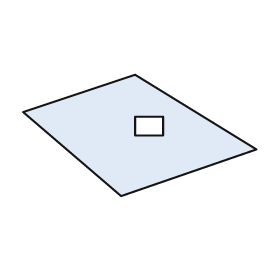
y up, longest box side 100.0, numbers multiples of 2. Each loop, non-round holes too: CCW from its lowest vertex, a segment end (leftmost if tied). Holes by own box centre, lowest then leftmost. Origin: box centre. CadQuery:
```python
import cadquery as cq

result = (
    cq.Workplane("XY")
    .moveTo(-8.0, -26.0)
    .lineTo(50.0, -6.0)
    .lineTo(-2.0, 26.0)
    .lineTo(-50.0, 10.0)
    .close()
    .moveTo(-2.0, 0.0)
    .lineTo(10.0, 0.0)
    .lineTo(10.0, 8.0)
    .lineTo(-2.0, 8.0)
    .close()
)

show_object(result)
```